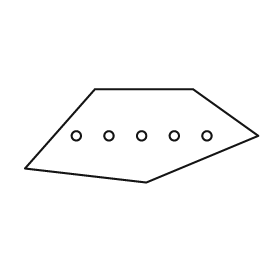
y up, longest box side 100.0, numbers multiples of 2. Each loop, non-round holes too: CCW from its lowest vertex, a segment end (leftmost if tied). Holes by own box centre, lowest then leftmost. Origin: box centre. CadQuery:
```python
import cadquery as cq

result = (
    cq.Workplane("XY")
    .moveTo(2.0, -20.0)
    .lineTo(50.0, 0.0)
    .lineTo(22.0, 20.0)
    .lineTo(-20.0, 20.0)
    .lineTo(-50.0, -14.0)
    .close()
    .moveTo(-28.0, 0.0)
    .circle(2.0)
    .moveTo(-14.0, 0.0)
    .circle(2.0)
    .moveTo(0.0, 0.0)
    .circle(2.0)
    .moveTo(14.0, 0.0)
    .circle(2.0)
    .moveTo(28.0, 0.0)
    .circle(2.0)
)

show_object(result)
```